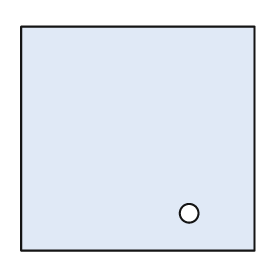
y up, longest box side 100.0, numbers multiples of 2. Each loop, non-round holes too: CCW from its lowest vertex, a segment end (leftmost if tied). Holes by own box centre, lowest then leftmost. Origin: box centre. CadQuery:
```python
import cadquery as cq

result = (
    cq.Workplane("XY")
    .moveTo(-50.0, -48.0)
    .lineTo(50.0, -48.0)
    .lineTo(50.0, 48.0)
    .lineTo(-50.0, 48.0)
    .close()
    .moveTo(22.0, -32.0)
    .circle(4.0)
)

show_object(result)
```